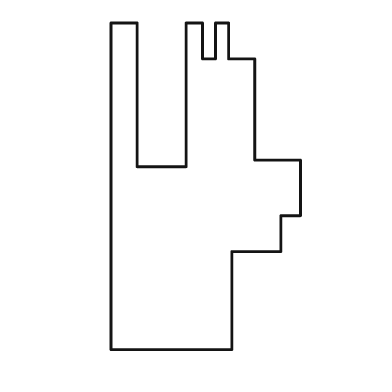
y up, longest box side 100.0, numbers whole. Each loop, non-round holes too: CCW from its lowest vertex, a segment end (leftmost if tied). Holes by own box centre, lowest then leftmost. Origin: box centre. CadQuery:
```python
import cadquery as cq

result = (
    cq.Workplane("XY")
    .moveTo(-29.0, -50.0)
    .lineTo(8.0, -50.0)
    .lineTo(8.0, -20.0)
    .lineTo(23.0, -20.0)
    .lineTo(23.0, -9.0)
    .lineTo(29.0, -9.0)
    .lineTo(29.0, 8.0)
    .lineTo(15.0, 8.0)
    .lineTo(15.0, 39.0)
    .lineTo(7.0, 39.0)
    .lineTo(7.0, 50.0)
    .lineTo(3.0, 50.0)
    .lineTo(3.0, 39.0)
    .lineTo(-1.0, 39.0)
    .lineTo(-1.0, 50.0)
    .lineTo(-6.0, 50.0)
    .lineTo(-6.0, 6.0)
    .lineTo(-21.0, 6.0)
    .lineTo(-21.0, 50.0)
    .lineTo(-29.0, 50.0)
    .close()
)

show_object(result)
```